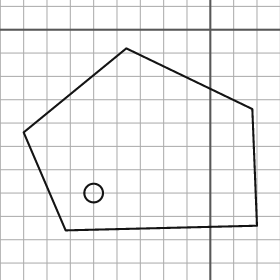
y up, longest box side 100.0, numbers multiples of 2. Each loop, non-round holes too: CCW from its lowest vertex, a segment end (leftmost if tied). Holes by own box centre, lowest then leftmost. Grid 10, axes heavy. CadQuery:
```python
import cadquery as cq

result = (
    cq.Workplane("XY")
    .moveTo(-62.0, -86.0)
    .lineTo(20.0, -84.0)
    .lineTo(18.0, -34.0)
    .lineTo(-36.0, -8.0)
    .lineTo(-80.0, -44.0)
    .close()
    .moveTo(-50.0, -70.0)
    .circle(4.0)
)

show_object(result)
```